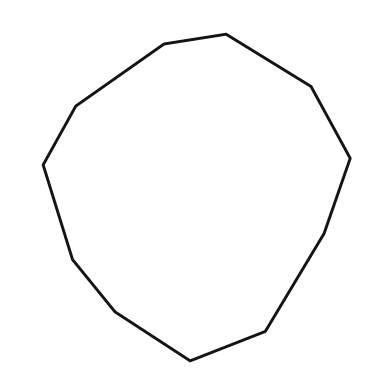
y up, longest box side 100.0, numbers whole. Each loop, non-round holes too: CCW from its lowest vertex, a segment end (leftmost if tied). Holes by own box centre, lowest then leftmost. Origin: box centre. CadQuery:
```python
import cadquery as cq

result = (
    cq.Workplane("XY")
    .moveTo(-2.0, -50.0)
    .lineTo(21.0, -41.0)
    .lineTo(39.0, -11.0)
    .lineTo(47.0, 12.0)
    .lineTo(35.0, 34.0)
    .lineTo(9.0, 50.0)
    .lineTo(-10.0, 47.0)
    .lineTo(-37.0, 28.0)
    .lineTo(-47.0, 10.0)
    .lineTo(-38.0, -19.0)
    .lineTo(-25.0, -35.0)
    .close()
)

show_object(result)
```